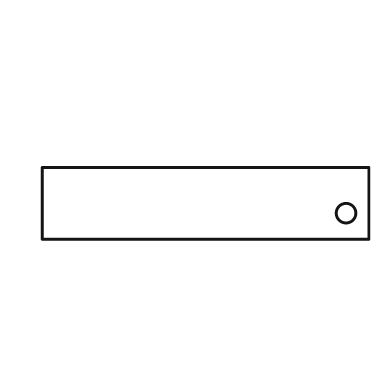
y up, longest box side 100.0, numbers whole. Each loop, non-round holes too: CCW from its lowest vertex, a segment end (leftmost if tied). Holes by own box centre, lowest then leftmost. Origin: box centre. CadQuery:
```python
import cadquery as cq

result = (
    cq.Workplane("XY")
    .moveTo(-50.0, -11.0)
    .lineTo(50.0, -11.0)
    .lineTo(50.0, 11.0)
    .lineTo(-50.0, 11.0)
    .close()
    .moveTo(43.0, -3.0)
    .circle(3.0)
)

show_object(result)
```